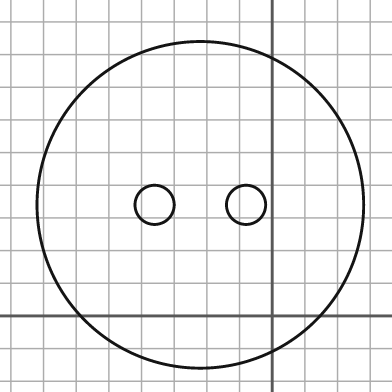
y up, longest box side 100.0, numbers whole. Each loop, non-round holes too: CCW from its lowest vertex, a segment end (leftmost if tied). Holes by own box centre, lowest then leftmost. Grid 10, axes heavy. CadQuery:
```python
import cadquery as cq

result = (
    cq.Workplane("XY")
    .moveTo(-22.0, 34.0)
    .circle(50.0)
    .moveTo(-36.0, 34.0)
    .circle(6.0)
    .moveTo(-8.0, 34.0)
    .circle(6.0)
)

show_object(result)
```